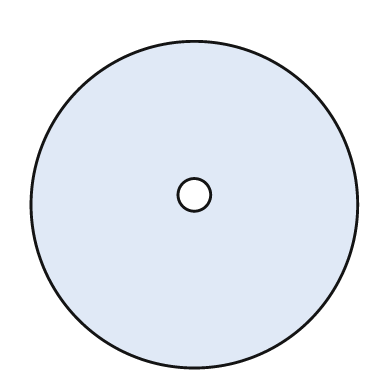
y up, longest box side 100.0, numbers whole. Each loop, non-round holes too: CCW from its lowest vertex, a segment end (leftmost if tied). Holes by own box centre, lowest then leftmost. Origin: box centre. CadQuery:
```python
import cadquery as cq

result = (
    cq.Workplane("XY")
    .moveTo(0.0, 0.0)
    .circle(50.0)
    .moveTo(0.0, 3.0)
    .circle(5.0)
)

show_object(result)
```